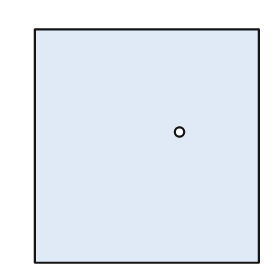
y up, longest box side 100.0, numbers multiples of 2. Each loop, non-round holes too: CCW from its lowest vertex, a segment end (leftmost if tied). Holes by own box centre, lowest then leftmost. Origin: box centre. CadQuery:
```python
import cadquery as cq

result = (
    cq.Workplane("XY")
    .moveTo(-48.0, -50.0)
    .lineTo(48.0, -50.0)
    .lineTo(48.0, 50.0)
    .lineTo(-48.0, 50.0)
    .close()
    .moveTo(14.0, 6.0)
    .circle(2.0)
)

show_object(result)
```